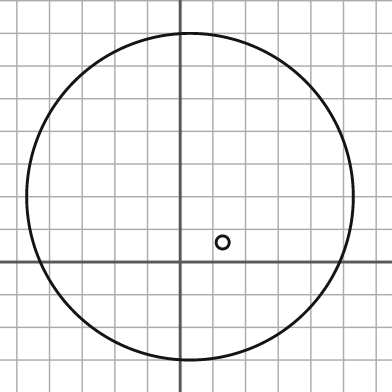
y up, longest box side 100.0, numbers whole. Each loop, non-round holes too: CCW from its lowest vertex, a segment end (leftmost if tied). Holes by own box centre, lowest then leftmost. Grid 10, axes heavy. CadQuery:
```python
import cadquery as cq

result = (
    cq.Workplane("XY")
    .moveTo(3.0, 20.0)
    .circle(50.0)
    .moveTo(13.0, 6.0)
    .circle(2.0)
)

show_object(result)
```